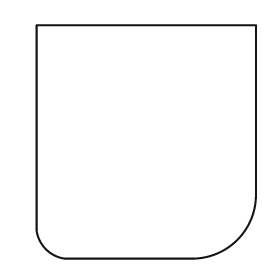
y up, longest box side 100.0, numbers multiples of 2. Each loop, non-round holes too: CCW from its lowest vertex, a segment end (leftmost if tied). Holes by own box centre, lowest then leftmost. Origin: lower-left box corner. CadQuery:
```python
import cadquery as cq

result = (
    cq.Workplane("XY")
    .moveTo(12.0, 0.0)
    .lineTo(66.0, 0.0)
    .threePointArc((86.0, 8.0), (94.0, 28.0))
    .lineTo(94.0, 100.0)
    .lineTo(0.0, 100.0)
    .lineTo(0.0, 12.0)
    .threePointArc((4.0, 4.0), (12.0, 0.0))
    .close()
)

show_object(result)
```